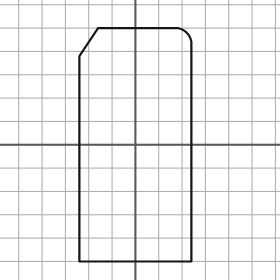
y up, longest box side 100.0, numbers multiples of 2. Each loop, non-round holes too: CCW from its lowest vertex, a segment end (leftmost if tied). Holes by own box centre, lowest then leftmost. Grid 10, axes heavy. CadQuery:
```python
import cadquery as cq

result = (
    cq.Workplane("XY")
    .moveTo(-24.0, -50.0)
    .lineTo(24.0, -50.0)
    .lineTo(24.0, 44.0)
    .threePointArc((22.0, 48.0), (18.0, 50.0))
    .lineTo(-16.0, 50.0)
    .lineTo(-24.0, 38.0)
    .close()
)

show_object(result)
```